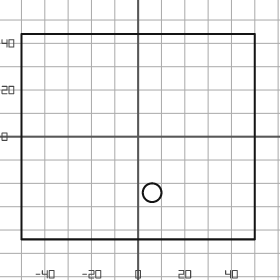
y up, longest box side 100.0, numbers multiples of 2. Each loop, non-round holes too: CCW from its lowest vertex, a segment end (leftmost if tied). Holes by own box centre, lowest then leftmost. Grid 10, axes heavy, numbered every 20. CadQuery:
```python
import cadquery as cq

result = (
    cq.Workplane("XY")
    .moveTo(-50.0, -44.0)
    .lineTo(50.0, -44.0)
    .lineTo(50.0, 44.0)
    .lineTo(-50.0, 44.0)
    .close()
    .moveTo(6.0, -24.0)
    .circle(4.0)
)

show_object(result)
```